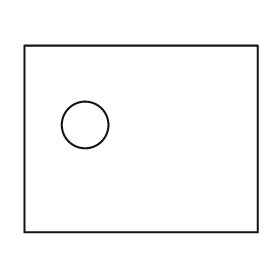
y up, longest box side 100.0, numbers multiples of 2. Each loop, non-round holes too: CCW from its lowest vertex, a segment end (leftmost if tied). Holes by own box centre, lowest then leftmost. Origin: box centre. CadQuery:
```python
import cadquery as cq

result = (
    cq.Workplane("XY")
    .moveTo(-50.0, -40.0)
    .lineTo(50.0, -40.0)
    .lineTo(50.0, 40.0)
    .lineTo(-50.0, 40.0)
    .close()
    .moveTo(-24.0, 6.0)
    .circle(10.0)
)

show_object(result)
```